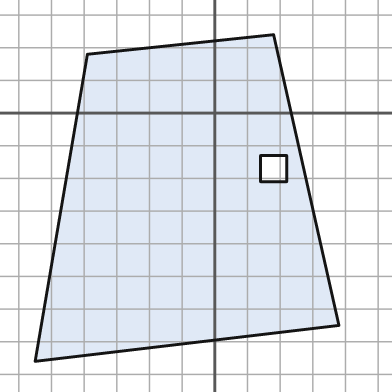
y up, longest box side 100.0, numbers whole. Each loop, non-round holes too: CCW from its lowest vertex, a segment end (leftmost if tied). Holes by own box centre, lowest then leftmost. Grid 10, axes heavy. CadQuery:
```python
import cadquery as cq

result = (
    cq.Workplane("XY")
    .moveTo(-55.0, -76.0)
    .lineTo(38.0, -65.0)
    .lineTo(18.0, 24.0)
    .lineTo(-39.0, 18.0)
    .close()
    .moveTo(14.0, -21.0)
    .lineTo(22.0, -21.0)
    .lineTo(22.0, -13.0)
    .lineTo(14.0, -13.0)
    .close()
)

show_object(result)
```